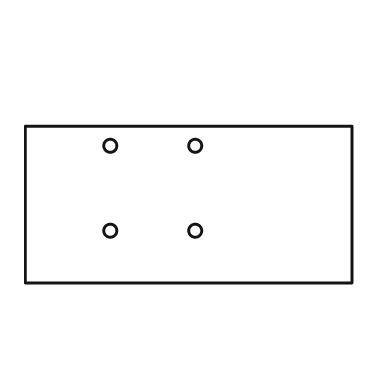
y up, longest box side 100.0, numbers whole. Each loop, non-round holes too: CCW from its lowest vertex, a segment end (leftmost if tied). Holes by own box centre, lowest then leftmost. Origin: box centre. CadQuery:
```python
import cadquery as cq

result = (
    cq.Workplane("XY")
    .moveTo(-50.0, -24.0)
    .lineTo(50.0, -24.0)
    .lineTo(50.0, 24.0)
    .lineTo(-50.0, 24.0)
    .close()
    .moveTo(-24.0, -8.0)
    .circle(2.0)
    .moveTo(2.0, -8.0)
    .circle(2.0)
    .moveTo(-24.0, 18.0)
    .circle(2.0)
    .moveTo(2.0, 18.0)
    .circle(2.0)
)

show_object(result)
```